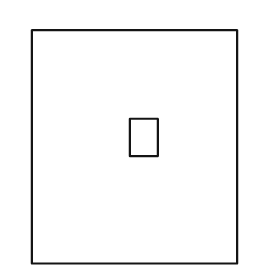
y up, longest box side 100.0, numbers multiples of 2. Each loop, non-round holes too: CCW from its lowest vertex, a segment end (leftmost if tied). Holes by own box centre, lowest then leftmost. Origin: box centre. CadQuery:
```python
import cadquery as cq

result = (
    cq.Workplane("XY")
    .moveTo(-44.0, -50.0)
    .lineTo(44.0, -50.0)
    .lineTo(44.0, 50.0)
    .lineTo(-44.0, 50.0)
    .close()
    .moveTo(-2.0, -4.0)
    .lineTo(10.0, -4.0)
    .lineTo(10.0, 12.0)
    .lineTo(-2.0, 12.0)
    .close()
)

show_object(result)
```